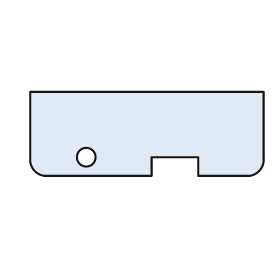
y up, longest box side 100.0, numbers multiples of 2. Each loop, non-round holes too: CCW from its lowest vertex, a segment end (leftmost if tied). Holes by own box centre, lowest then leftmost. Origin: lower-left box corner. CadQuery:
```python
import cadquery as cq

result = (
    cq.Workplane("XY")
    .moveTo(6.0, 0.0)
    .lineTo(52.0, 0.0)
    .lineTo(52.0, 8.0)
    .lineTo(72.0, 8.0)
    .lineTo(72.0, 0.0)
    .lineTo(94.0, 0.0)
    .threePointArc((98.0, 2.0), (100.0, 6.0))
    .lineTo(100.0, 36.0)
    .lineTo(0.0, 36.0)
    .lineTo(0.0, 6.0)
    .threePointArc((2.0, 2.0), (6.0, 0.0))
    .close()
    .moveTo(24.0, 8.0)
    .circle(4.0)
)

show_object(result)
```